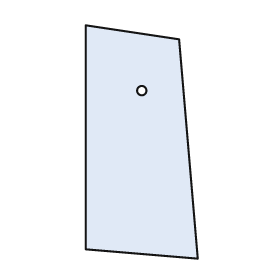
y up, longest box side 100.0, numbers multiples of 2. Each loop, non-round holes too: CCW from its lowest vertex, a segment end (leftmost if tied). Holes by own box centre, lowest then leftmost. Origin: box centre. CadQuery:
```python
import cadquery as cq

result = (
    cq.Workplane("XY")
    .moveTo(24.0, -50.0)
    .lineTo(16.0, 44.0)
    .lineTo(-24.0, 50.0)
    .lineTo(-24.0, -46.0)
    .close()
    .moveTo(0.0, 22.0)
    .circle(2.0)
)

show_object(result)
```